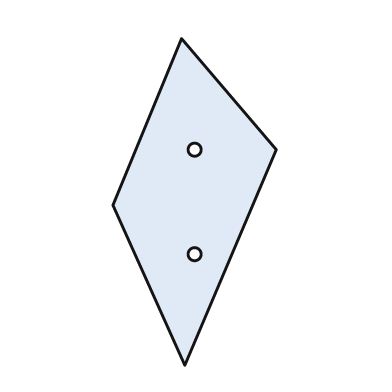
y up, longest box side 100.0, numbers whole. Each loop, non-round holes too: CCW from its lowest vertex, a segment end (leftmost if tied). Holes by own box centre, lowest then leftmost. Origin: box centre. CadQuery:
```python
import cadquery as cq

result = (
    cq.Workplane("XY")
    .moveTo(-3.0, -50.0)
    .lineTo(25.0, 16.0)
    .lineTo(-4.0, 50.0)
    .lineTo(-25.0, -1.0)
    .close()
    .moveTo(0.0, -16.0)
    .circle(2.0)
    .moveTo(0.0, 16.0)
    .circle(2.0)
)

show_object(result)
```